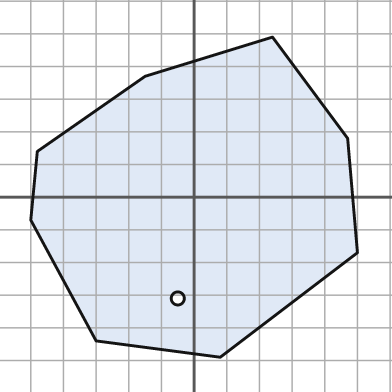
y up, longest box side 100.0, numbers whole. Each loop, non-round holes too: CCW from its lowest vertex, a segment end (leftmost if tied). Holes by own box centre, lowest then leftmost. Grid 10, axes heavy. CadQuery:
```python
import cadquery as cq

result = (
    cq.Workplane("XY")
    .moveTo(8.0, -49.0)
    .lineTo(50.0, -17.0)
    .lineTo(47.0, 18.0)
    .lineTo(24.0, 49.0)
    .lineTo(-15.0, 37.0)
    .lineTo(-48.0, 14.0)
    .lineTo(-50.0, -7.0)
    .lineTo(-30.0, -44.0)
    .close()
    .moveTo(-5.0, -31.0)
    .circle(2.0)
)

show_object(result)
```